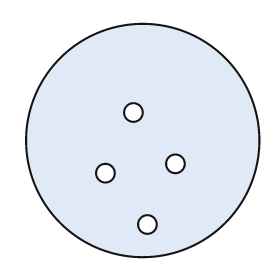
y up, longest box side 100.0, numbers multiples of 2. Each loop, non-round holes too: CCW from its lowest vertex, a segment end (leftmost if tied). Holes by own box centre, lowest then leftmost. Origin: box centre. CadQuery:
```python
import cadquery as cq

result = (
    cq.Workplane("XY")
    .moveTo(0.0, 0.0)
    .circle(50.0)
    .moveTo(2.0, -36.0)
    .circle(4.0)
    .moveTo(-16.0, -14.0)
    .circle(4.0)
    .moveTo(14.0, -10.0)
    .circle(4.0)
    .moveTo(-4.0, 12.0)
    .circle(4.0)
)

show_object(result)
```